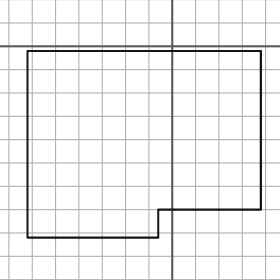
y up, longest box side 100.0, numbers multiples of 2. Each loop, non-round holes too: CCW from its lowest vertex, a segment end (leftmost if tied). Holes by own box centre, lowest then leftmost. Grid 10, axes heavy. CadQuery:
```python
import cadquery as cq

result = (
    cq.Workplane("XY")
    .moveTo(-62.0, -82.0)
    .lineTo(-6.0, -82.0)
    .lineTo(-6.0, -70.0)
    .lineTo(38.0, -70.0)
    .lineTo(38.0, -2.0)
    .lineTo(-62.0, -2.0)
    .close()
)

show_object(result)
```